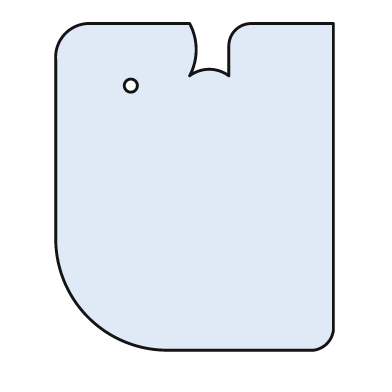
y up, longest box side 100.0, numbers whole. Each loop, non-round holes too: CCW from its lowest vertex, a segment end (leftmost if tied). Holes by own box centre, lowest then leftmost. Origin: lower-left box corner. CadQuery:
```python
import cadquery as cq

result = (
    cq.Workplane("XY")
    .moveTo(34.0, 0.0)
    .lineTo(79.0, 0.0)
    .threePointArc((83.0, 2.0), (85.0, 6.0))
    .lineTo(85.0, 100.0)
    .lineTo(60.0, 100.0)
    .threePointArc((55.0, 98.0), (53.0, 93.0))
    .lineTo(53.0, 84.0)
    .threePointArc((47.0, 86.0), (41.0, 84.0))
    .threePointArc((43.0, 92.0), (41.0, 100.0))
    .lineTo(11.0, 100.0)
    .threePointArc((3.0, 97.0), (0.0, 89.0))
    .lineTo(0.0, 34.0)
    .threePointArc((10.0, 10.0), (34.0, 0.0))
    .close()
    .moveTo(23.0, 81.0)
    .circle(2.0)
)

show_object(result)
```